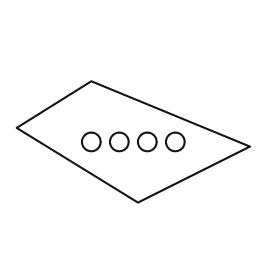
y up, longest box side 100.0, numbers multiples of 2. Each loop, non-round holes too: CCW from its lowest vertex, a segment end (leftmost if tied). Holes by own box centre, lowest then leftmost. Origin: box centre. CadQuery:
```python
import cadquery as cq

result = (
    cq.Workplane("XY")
    .moveTo(2.0, -26.0)
    .lineTo(50.0, -2.0)
    .lineTo(-18.0, 26.0)
    .lineTo(-50.0, 6.0)
    .close()
    .moveTo(-18.0, 0.0)
    .circle(4.0)
    .moveTo(-6.0, 0.0)
    .circle(4.0)
    .moveTo(6.0, 0.0)
    .circle(4.0)
    .moveTo(18.0, 0.0)
    .circle(4.0)
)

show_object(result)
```